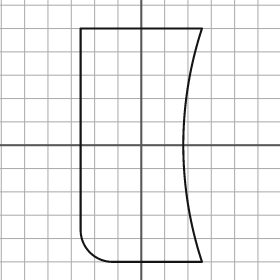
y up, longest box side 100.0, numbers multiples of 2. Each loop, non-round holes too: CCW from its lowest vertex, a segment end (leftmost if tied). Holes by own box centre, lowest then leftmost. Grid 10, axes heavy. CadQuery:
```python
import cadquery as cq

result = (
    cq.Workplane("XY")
    .moveTo(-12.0, -50.0)
    .lineTo(26.0, -50.0)
    .threePointArc((18.0, 0.0), (26.0, 50.0))
    .lineTo(-26.0, 50.0)
    .lineTo(-26.0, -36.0)
    .threePointArc((-22.0, -46.0), (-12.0, -50.0))
    .close()
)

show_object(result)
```